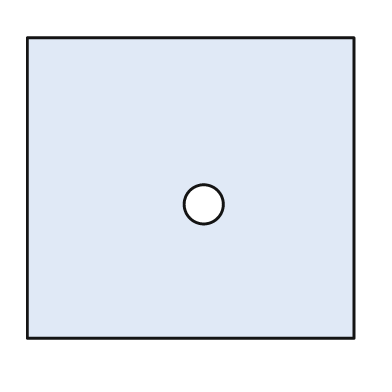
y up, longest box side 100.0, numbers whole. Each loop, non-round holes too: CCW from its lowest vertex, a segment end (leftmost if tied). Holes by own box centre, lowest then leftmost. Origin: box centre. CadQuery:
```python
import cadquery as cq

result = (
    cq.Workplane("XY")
    .moveTo(-50.0, -46.0)
    .lineTo(50.0, -46.0)
    .lineTo(50.0, 46.0)
    .lineTo(-50.0, 46.0)
    .close()
    .moveTo(4.0, -5.0)
    .circle(6.0)
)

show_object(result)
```